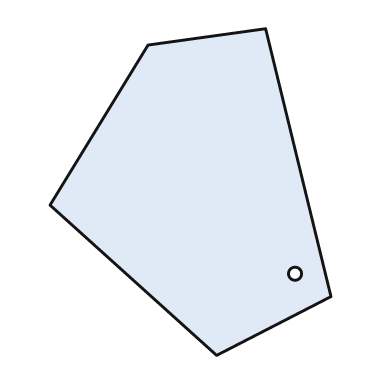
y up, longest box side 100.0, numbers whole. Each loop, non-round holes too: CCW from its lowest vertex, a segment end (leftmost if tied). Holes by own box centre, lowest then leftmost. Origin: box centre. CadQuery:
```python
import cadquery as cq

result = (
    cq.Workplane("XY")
    .moveTo(8.0, -50.0)
    .lineTo(43.0, -32.0)
    .lineTo(23.0, 50.0)
    .lineTo(-13.0, 45.0)
    .lineTo(-43.0, -4.0)
    .close()
    .moveTo(32.0, -25.0)
    .circle(2.0)
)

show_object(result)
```